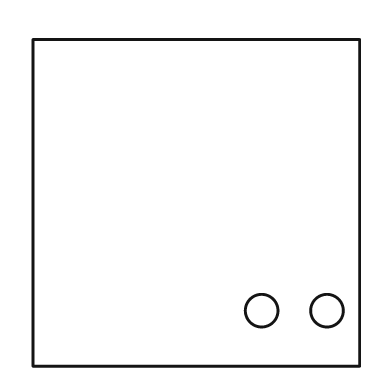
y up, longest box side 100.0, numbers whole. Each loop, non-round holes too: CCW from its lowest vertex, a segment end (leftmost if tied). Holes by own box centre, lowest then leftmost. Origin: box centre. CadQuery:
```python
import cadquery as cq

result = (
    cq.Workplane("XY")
    .moveTo(-50.0, -50.0)
    .lineTo(50.0, -50.0)
    .lineTo(50.0, 50.0)
    .lineTo(-50.0, 50.0)
    .close()
    .moveTo(20.0, -33.0)
    .circle(5.0)
    .moveTo(40.0, -33.0)
    .circle(5.0)
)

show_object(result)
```